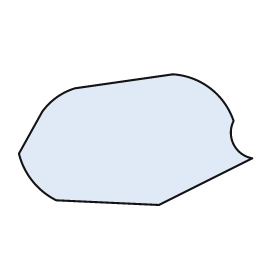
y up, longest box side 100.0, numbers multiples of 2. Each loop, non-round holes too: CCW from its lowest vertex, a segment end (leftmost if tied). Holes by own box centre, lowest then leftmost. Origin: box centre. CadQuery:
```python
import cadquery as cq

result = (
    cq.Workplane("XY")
    .moveTo(10.0, -28.0)
    .lineTo(50.0, -8.0)
    .threePointArc((42.0, -2.0), (42.0, 8.0))
    .threePointArc((32.0, 22.0), (16.0, 28.0))
    .lineTo(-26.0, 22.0)
    .threePointArc((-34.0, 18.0), (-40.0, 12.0))
    .lineTo(-50.0, -6.0)
    .threePointArc((-44.0, -18.0), (-34.0, -26.0))
    .close()
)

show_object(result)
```